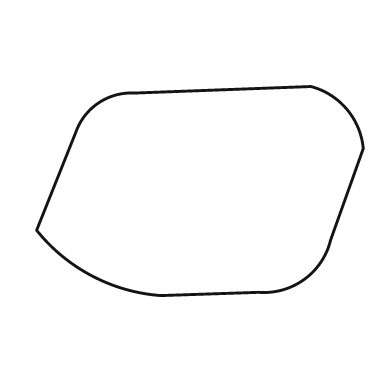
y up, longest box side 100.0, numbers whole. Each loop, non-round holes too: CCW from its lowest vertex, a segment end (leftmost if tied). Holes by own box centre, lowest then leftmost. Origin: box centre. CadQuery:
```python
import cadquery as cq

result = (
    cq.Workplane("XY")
    .moveTo(-12.0, -32.0)
    .lineTo(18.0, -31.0)
    .threePointArc((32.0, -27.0), (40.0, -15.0))
    .lineTo(50.0, 13.0)
    .threePointArc((45.0, 25.0), (34.0, 32.0))
    .lineTo(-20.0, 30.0)
    .threePointArc((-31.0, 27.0), (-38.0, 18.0))
    .lineTo(-50.0, -12.0)
    .threePointArc((-33.0, -26.0), (-12.0, -32.0))
    .close()
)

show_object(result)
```